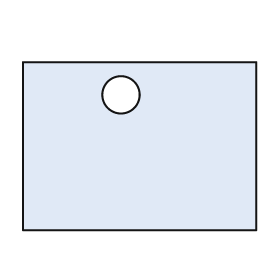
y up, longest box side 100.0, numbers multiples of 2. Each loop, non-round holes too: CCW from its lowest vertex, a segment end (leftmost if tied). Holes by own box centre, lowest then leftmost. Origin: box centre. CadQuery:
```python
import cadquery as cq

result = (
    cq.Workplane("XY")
    .moveTo(-50.0, -36.0)
    .lineTo(50.0, -36.0)
    .lineTo(50.0, 36.0)
    .lineTo(-50.0, 36.0)
    .close()
    .moveTo(-8.0, 22.0)
    .circle(8.0)
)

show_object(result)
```